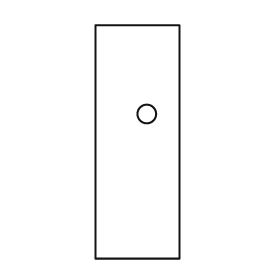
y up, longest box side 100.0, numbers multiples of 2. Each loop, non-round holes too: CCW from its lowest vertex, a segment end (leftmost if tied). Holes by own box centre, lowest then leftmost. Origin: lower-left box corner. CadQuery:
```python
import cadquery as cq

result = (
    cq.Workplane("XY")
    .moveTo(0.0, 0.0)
    .lineTo(36.0, 0.0)
    .lineTo(36.0, 100.0)
    .lineTo(0.0, 100.0)
    .close()
    .moveTo(22.0, 62.0)
    .circle(4.0)
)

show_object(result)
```